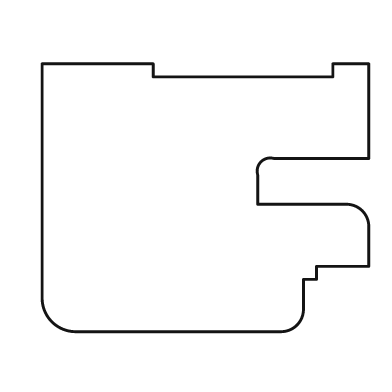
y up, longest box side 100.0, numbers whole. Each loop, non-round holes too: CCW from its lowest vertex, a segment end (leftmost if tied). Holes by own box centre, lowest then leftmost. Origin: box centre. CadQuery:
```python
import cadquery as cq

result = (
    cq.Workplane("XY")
    .moveTo(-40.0, -41.0)
    .lineTo(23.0, -41.0)
    .threePointArc((28.0, -39.0), (30.0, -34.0))
    .lineTo(30.0, -25.0)
    .lineTo(34.0, -25.0)
    .lineTo(34.0, -21.0)
    .lineTo(50.0, -21.0)
    .lineTo(50.0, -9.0)
    .threePointArc((48.0, -4.0), (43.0, -2.0))
    .lineTo(16.0, -2.0)
    .lineTo(16.0, 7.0)
    .threePointArc((17.0, 11.0), (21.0, 12.0))
    .lineTo(50.0, 12.0)
    .lineTo(50.0, 41.0)
    .lineTo(39.0, 41.0)
    .lineTo(39.0, 37.0)
    .lineTo(-16.0, 37.0)
    .lineTo(-16.0, 41.0)
    .lineTo(-50.0, 41.0)
    .lineTo(-50.0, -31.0)
    .threePointArc((-47.0, -38.0), (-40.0, -41.0))
    .close()
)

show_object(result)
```